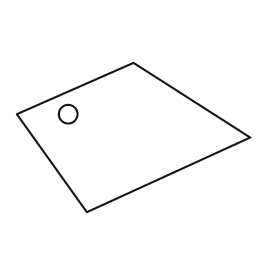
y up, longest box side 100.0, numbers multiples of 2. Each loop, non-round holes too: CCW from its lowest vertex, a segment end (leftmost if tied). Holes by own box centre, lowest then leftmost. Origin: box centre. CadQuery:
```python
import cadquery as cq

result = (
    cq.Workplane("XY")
    .moveTo(-20.0, -32.0)
    .lineTo(50.0, 0.0)
    .lineTo(0.0, 32.0)
    .lineTo(-50.0, 10.0)
    .close()
    .moveTo(-28.0, 10.0)
    .circle(4.0)
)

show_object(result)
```